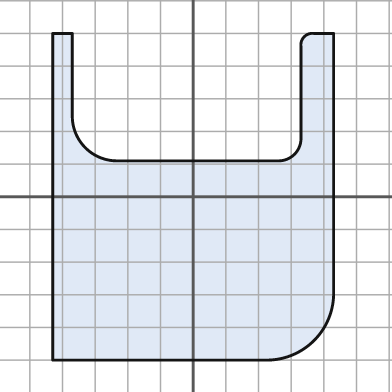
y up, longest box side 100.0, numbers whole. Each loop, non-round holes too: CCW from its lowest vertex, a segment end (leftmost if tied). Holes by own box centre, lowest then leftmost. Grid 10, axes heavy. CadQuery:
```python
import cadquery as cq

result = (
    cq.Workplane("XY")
    .moveTo(-43.0, -50.0)
    .lineTo(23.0, -50.0)
    .threePointArc((37.0, -44.0), (43.0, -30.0))
    .lineTo(43.0, 50.0)
    .lineTo(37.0, 50.0)
    .threePointArc((34.0, 49.0), (33.0, 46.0))
    .lineTo(33.0, 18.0)
    .threePointArc((31.0, 13.0), (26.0, 11.0))
    .lineTo(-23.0, 11.0)
    .threePointArc((-33.0, 15.0), (-37.0, 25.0))
    .lineTo(-37.0, 50.0)
    .lineTo(-43.0, 50.0)
    .close()
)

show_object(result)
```